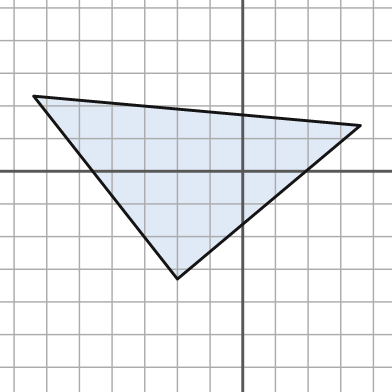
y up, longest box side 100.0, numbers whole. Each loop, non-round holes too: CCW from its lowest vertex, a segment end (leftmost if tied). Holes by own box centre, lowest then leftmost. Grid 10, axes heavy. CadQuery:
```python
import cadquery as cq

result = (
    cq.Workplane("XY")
    .moveTo(-20.0, -33.0)
    .lineTo(36.0, 14.0)
    .lineTo(-64.0, 23.0)
    .close()
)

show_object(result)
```